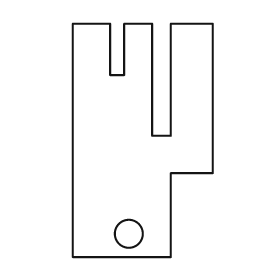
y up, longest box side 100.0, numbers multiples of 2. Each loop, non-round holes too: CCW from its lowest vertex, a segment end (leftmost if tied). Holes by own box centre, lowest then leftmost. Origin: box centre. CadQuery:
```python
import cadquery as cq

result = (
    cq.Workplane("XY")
    .moveTo(-30.0, -50.0)
    .lineTo(12.0, -50.0)
    .lineTo(12.0, -14.0)
    .lineTo(30.0, -14.0)
    .lineTo(30.0, 50.0)
    .lineTo(12.0, 50.0)
    .lineTo(12.0, 2.0)
    .lineTo(4.0, 2.0)
    .lineTo(4.0, 50.0)
    .lineTo(-8.0, 50.0)
    .lineTo(-8.0, 28.0)
    .lineTo(-14.0, 28.0)
    .lineTo(-14.0, 50.0)
    .lineTo(-30.0, 50.0)
    .close()
    .moveTo(-6.0, -40.0)
    .circle(6.0)
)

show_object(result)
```